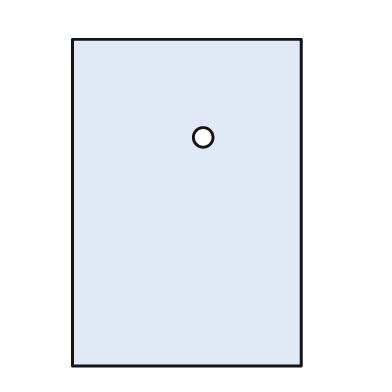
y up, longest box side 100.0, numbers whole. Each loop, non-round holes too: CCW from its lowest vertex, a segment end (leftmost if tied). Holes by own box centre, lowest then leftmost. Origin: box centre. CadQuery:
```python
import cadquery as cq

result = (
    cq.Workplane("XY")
    .moveTo(-35.0, -50.0)
    .lineTo(35.0, -50.0)
    .lineTo(35.0, 50.0)
    .lineTo(-35.0, 50.0)
    .close()
    .moveTo(5.0, 20.0)
    .circle(3.0)
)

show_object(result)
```